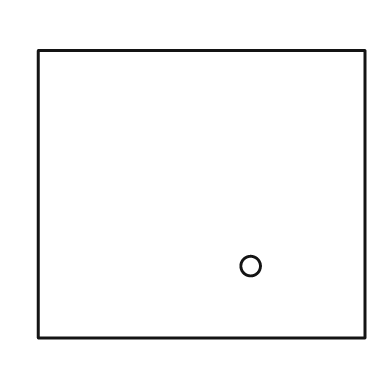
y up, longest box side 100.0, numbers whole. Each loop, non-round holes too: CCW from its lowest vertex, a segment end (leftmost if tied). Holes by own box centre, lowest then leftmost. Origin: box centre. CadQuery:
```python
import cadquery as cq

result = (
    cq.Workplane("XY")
    .moveTo(-50.0, -44.0)
    .lineTo(50.0, -44.0)
    .lineTo(50.0, 44.0)
    .lineTo(-50.0, 44.0)
    .close()
    .moveTo(15.0, -22.0)
    .circle(3.0)
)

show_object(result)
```